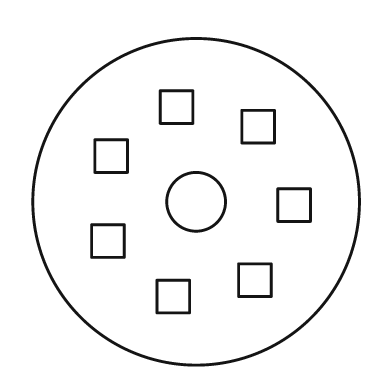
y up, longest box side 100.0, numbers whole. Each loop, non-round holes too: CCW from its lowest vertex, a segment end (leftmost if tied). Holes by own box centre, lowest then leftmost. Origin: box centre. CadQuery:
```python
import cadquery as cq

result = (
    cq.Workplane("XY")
    .moveTo(0.0, 0.0)
    .circle(50.0)
    .moveTo(-12.0, -34.0)
    .lineTo(-2.0, -34.0)
    .lineTo(-2.0, -24.0)
    .lineTo(-12.0, -24.0)
    .close()
    .moveTo(13.0, -29.0)
    .lineTo(23.0, -29.0)
    .lineTo(23.0, -19.0)
    .lineTo(13.0, -19.0)
    .close()
    .moveTo(-32.0, -17.0)
    .lineTo(-22.0, -17.0)
    .lineTo(-22.0, -7.0)
    .lineTo(-32.0, -7.0)
    .close()
    .moveTo(25.0, -6.0)
    .lineTo(35.0, -6.0)
    .lineTo(35.0, 4.0)
    .lineTo(25.0, 4.0)
    .close()
    .moveTo(0.0, 0.0)
    .circle(9.0)
    .moveTo(-31.0, 9.0)
    .lineTo(-21.0, 9.0)
    .lineTo(-21.0, 19.0)
    .lineTo(-31.0, 19.0)
    .close()
    .moveTo(14.0, 18.0)
    .lineTo(24.0, 18.0)
    .lineTo(24.0, 28.0)
    .lineTo(14.0, 28.0)
    .close()
    .moveTo(-11.0, 24.0)
    .lineTo(-1.0, 24.0)
    .lineTo(-1.0, 34.0)
    .lineTo(-11.0, 34.0)
    .close()
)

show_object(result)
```